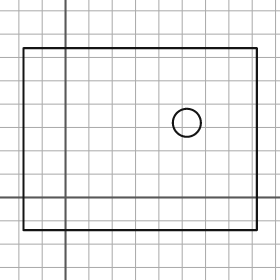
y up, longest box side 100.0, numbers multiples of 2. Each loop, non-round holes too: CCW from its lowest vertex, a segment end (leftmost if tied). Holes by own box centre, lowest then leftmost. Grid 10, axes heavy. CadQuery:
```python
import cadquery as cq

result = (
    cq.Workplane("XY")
    .moveTo(-18.0, -14.0)
    .lineTo(82.0, -14.0)
    .lineTo(82.0, 64.0)
    .lineTo(-18.0, 64.0)
    .close()
    .moveTo(52.0, 32.0)
    .circle(6.0)
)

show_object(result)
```